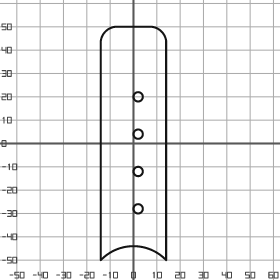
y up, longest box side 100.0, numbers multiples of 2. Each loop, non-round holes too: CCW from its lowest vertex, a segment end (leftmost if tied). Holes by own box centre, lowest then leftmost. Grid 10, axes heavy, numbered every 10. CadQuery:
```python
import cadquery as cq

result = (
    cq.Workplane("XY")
    .moveTo(-14.0, -50.0)
    .threePointArc((0.0, -44.0), (14.0, -50.0))
    .lineTo(14.0, 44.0)
    .threePointArc((12.0, 48.0), (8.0, 50.0))
    .lineTo(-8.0, 50.0)
    .threePointArc((-12.0, 48.0), (-14.0, 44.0))
    .close()
    .moveTo(2.0, -28.0)
    .circle(2.0)
    .moveTo(2.0, -12.0)
    .circle(2.0)
    .moveTo(2.0, 4.0)
    .circle(2.0)
    .moveTo(2.0, 20.0)
    .circle(2.0)
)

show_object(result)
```